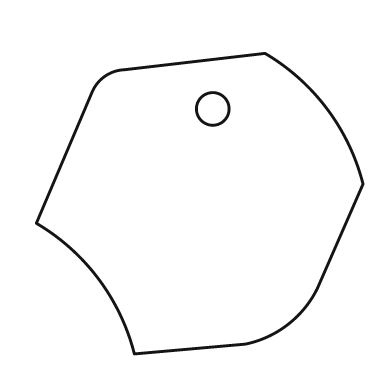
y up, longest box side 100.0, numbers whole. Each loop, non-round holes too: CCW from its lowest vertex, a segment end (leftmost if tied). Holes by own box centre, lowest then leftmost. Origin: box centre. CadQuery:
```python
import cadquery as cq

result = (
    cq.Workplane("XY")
    .moveTo(-20.0, -46.0)
    .lineTo(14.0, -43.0)
    .threePointArc((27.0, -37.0), (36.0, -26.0))
    .lineTo(50.0, 6.0)
    .threePointArc((39.0, 29.0), (20.0, 46.0))
    .lineTo(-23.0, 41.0)
    .threePointArc((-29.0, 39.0), (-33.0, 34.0))
    .lineTo(-50.0, -6.0)
    .threePointArc((-31.0, -23.0), (-20.0, -46.0))
    .close()
    .moveTo(4.0, 29.0)
    .circle(5.0)
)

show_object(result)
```